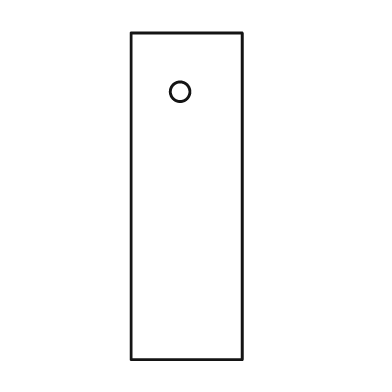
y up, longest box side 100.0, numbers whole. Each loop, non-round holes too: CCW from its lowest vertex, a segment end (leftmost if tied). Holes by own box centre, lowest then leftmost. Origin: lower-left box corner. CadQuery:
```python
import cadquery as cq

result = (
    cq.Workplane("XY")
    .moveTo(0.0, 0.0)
    .lineTo(34.0, 0.0)
    .lineTo(34.0, 100.0)
    .lineTo(0.0, 100.0)
    .close()
    .moveTo(15.0, 82.0)
    .circle(3.0)
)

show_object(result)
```